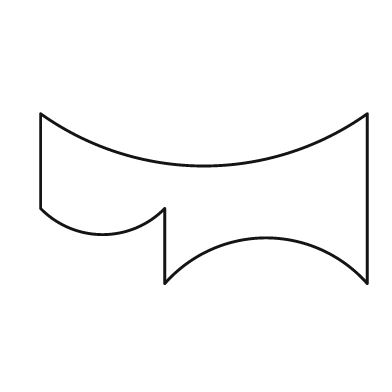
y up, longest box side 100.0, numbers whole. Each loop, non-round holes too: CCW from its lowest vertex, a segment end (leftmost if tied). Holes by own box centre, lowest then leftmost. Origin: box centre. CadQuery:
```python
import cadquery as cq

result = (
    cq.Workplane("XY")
    .moveTo(-12.0, -26.0)
    .threePointArc((19.0, -12.0), (50.0, -26.0))
    .lineTo(50.0, 26.0)
    .threePointArc((0.0, 10.0), (-50.0, 26.0))
    .lineTo(-50.0, -3.0)
    .threePointArc((-31.0, -11.0), (-12.0, -3.0))
    .close()
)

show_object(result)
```